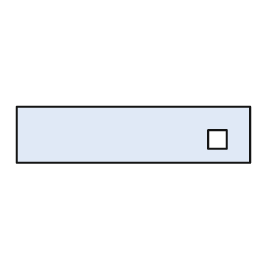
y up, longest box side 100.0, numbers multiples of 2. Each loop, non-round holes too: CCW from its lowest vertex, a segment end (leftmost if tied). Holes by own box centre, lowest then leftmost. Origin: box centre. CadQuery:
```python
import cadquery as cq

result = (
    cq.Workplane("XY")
    .moveTo(-50.0, -12.0)
    .lineTo(50.0, -12.0)
    .lineTo(50.0, 12.0)
    .lineTo(-50.0, 12.0)
    .close()
    .moveTo(32.0, -6.0)
    .lineTo(40.0, -6.0)
    .lineTo(40.0, 2.0)
    .lineTo(32.0, 2.0)
    .close()
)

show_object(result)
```